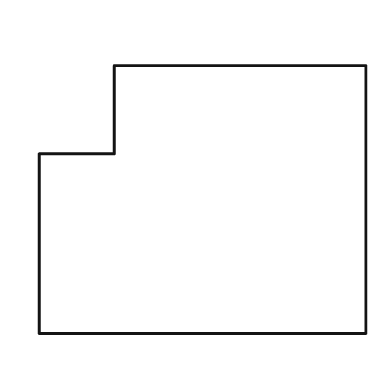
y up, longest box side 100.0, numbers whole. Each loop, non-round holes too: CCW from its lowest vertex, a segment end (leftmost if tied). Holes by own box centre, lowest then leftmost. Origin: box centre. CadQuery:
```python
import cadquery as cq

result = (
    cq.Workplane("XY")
    .moveTo(-50.0, -41.0)
    .lineTo(50.0, -41.0)
    .lineTo(50.0, 41.0)
    .lineTo(-27.0, 41.0)
    .lineTo(-27.0, 14.0)
    .lineTo(-50.0, 14.0)
    .close()
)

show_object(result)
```